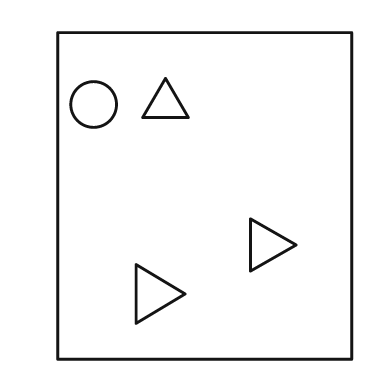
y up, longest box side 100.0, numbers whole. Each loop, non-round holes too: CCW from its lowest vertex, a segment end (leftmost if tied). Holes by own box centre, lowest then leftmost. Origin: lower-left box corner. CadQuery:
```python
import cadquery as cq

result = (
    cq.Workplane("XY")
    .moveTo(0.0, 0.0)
    .lineTo(90.0, 0.0)
    .lineTo(90.0, 100.0)
    .lineTo(0.0, 100.0)
    .close()
    .moveTo(24.0, 11.0)
    .lineTo(39.0, 20.0)
    .lineTo(24.0, 29.0)
    .close()
    .moveTo(59.0, 27.0)
    .lineTo(73.0, 35.0)
    .lineTo(59.0, 43.0)
    .close()
    .moveTo(11.0, 78.0)
    .circle(7.0)
    .moveTo(26.0, 74.0)
    .lineTo(40.0, 74.0)
    .lineTo(33.0, 86.0)
    .close()
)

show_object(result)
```